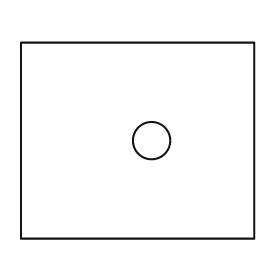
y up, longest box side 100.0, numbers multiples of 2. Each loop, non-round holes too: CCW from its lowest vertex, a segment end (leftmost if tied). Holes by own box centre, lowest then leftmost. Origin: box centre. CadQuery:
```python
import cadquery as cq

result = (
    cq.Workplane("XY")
    .moveTo(-50.0, -42.0)
    .lineTo(50.0, -42.0)
    .lineTo(50.0, 42.0)
    .lineTo(-50.0, 42.0)
    .close()
    .moveTo(6.0, 0.0)
    .circle(8.0)
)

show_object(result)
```